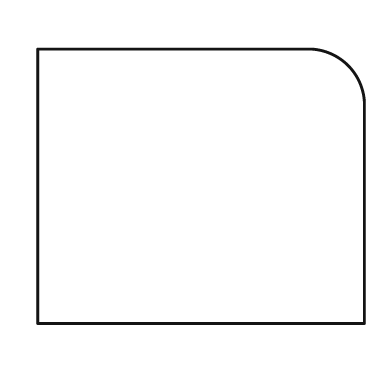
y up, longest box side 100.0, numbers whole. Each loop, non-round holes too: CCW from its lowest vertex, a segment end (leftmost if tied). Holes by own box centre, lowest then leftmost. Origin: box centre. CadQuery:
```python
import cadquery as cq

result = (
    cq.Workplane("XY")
    .moveTo(-50.0, -42.0)
    .lineTo(50.0, -42.0)
    .lineTo(50.0, 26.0)
    .threePointArc((45.0, 37.0), (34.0, 42.0))
    .lineTo(-50.0, 42.0)
    .close()
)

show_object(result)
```